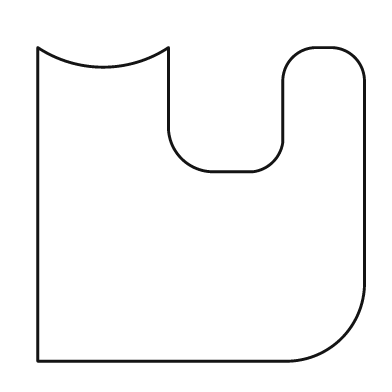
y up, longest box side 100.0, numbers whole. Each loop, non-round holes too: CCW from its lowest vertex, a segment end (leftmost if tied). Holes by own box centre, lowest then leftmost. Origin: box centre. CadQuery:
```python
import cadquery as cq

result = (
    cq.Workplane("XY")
    .moveTo(-50.0, -48.0)
    .lineTo(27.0, -48.0)
    .threePointArc((43.0, -41.0), (50.0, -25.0))
    .lineTo(50.0, 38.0)
    .threePointArc((47.0, 45.0), (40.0, 48.0))
    .lineTo(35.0, 48.0)
    .threePointArc((28.0, 45.0), (25.0, 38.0))
    .lineTo(25.0, 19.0)
    .threePointArc((22.0, 13.0), (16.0, 10.0))
    .lineTo(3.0, 10.0)
    .threePointArc((-6.0, 14.0), (-10.0, 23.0))
    .lineTo(-10.0, 48.0)
    .threePointArc((-30.0, 42.0), (-50.0, 48.0))
    .close()
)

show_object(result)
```